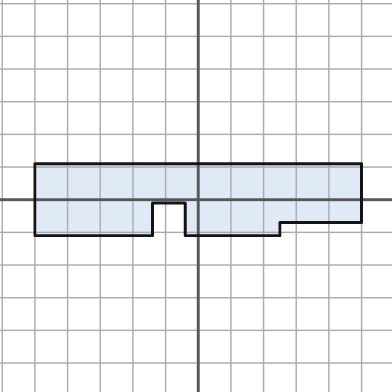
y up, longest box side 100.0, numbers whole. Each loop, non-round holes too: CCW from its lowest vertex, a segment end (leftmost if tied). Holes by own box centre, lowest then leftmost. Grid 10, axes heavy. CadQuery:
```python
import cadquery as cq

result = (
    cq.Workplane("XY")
    .moveTo(-50.0, -11.0)
    .lineTo(-14.0, -11.0)
    .lineTo(-14.0, -1.0)
    .lineTo(-4.0, -1.0)
    .lineTo(-4.0, -11.0)
    .lineTo(25.0, -11.0)
    .lineTo(25.0, -7.0)
    .lineTo(50.0, -7.0)
    .lineTo(50.0, 11.0)
    .lineTo(-50.0, 11.0)
    .close()
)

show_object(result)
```